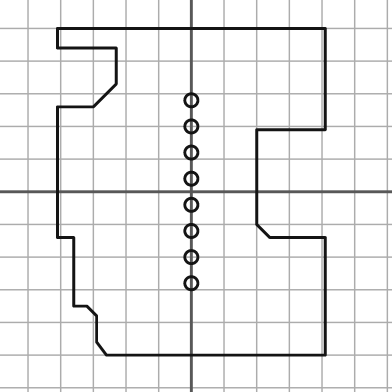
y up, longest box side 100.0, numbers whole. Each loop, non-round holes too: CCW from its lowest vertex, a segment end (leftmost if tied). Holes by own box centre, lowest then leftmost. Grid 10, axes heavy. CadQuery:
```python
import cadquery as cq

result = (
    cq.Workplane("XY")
    .moveTo(-26.0, -50.0)
    .lineTo(41.0, -50.0)
    .lineTo(41.0, -14.0)
    .lineTo(24.0, -14.0)
    .lineTo(20.0, -10.0)
    .lineTo(20.0, 19.0)
    .lineTo(41.0, 19.0)
    .lineTo(41.0, 50.0)
    .lineTo(-41.0, 50.0)
    .lineTo(-41.0, 44.0)
    .lineTo(-23.0, 44.0)
    .lineTo(-23.0, 33.0)
    .lineTo(-30.0, 26.0)
    .lineTo(-41.0, 26.0)
    .lineTo(-41.0, -14.0)
    .lineTo(-36.0, -14.0)
    .lineTo(-36.0, -35.0)
    .lineTo(-32.0, -35.0)
    .lineTo(-29.0, -38.0)
    .lineTo(-29.0, -46.0)
    .close()
    .moveTo(0.0, -28.0)
    .circle(2.0)
    .moveTo(0.0, -20.0)
    .circle(2.0)
    .moveTo(0.0, -12.0)
    .circle(2.0)
    .moveTo(0.0, -4.0)
    .circle(2.0)
    .moveTo(0.0, 4.0)
    .circle(2.0)
    .moveTo(0.0, 12.0)
    .circle(2.0)
    .moveTo(0.0, 20.0)
    .circle(2.0)
    .moveTo(0.0, 28.0)
    .circle(2.0)
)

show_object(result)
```